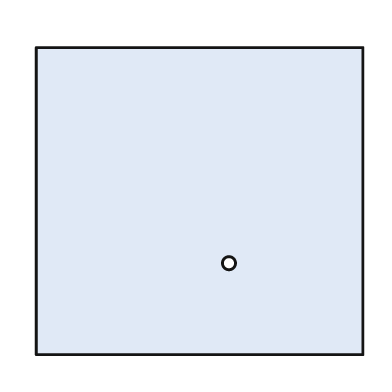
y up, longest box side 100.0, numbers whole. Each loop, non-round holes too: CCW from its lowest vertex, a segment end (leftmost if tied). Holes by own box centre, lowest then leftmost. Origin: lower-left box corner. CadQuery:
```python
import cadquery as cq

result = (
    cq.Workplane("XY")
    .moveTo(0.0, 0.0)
    .lineTo(100.0, 0.0)
    .lineTo(100.0, 94.0)
    .lineTo(0.0, 94.0)
    .close()
    .moveTo(59.0, 28.0)
    .circle(2.0)
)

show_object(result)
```